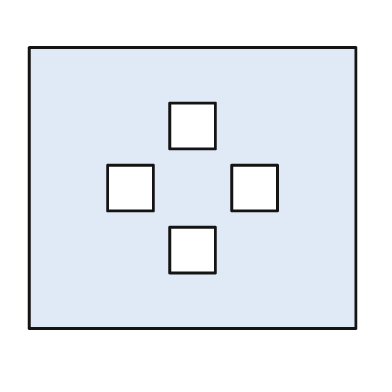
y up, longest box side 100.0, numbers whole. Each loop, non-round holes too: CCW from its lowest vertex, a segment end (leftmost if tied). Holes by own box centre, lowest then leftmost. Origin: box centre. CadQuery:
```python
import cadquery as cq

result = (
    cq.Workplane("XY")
    .moveTo(-50.0, -43.0)
    .lineTo(50.0, -43.0)
    .lineTo(50.0, 43.0)
    .lineTo(-50.0, 43.0)
    .close()
    .moveTo(-7.0, -26.0)
    .lineTo(7.0, -26.0)
    .lineTo(7.0, -12.0)
    .lineTo(-7.0, -12.0)
    .close()
    .moveTo(-26.0, -7.0)
    .lineTo(-12.0, -7.0)
    .lineTo(-12.0, 7.0)
    .lineTo(-26.0, 7.0)
    .close()
    .moveTo(12.0, -7.0)
    .lineTo(26.0, -7.0)
    .lineTo(26.0, 7.0)
    .lineTo(12.0, 7.0)
    .close()
    .moveTo(-7.0, 12.0)
    .lineTo(7.0, 12.0)
    .lineTo(7.0, 26.0)
    .lineTo(-7.0, 26.0)
    .close()
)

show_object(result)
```